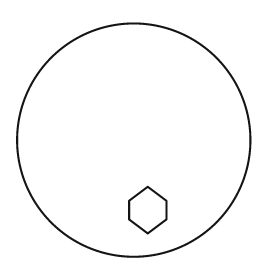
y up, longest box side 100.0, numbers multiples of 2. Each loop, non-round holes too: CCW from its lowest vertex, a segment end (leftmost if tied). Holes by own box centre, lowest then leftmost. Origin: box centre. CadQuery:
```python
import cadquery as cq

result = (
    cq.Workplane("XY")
    .moveTo(0.0, 0.0)
    .circle(50.0)
    .moveTo(6.0, -40.0)
    .lineTo(14.0, -34.0)
    .lineTo(14.0, -26.0)
    .lineTo(6.0, -20.0)
    .lineTo(-2.0, -26.0)
    .lineTo(-2.0, -34.0)
    .close()
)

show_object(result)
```